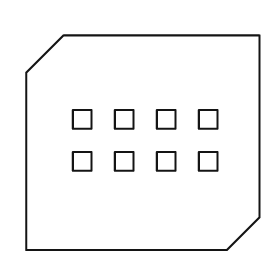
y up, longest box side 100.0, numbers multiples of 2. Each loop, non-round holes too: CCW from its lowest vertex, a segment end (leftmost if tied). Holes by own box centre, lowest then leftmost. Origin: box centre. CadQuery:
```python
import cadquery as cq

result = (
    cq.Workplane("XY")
    .moveTo(-50.0, -46.0)
    .lineTo(36.0, -46.0)
    .lineTo(50.0, -32.0)
    .lineTo(50.0, 46.0)
    .lineTo(-34.0, 46.0)
    .lineTo(-50.0, 30.0)
    .close()
    .moveTo(-30.0, -12.0)
    .lineTo(-22.0, -12.0)
    .lineTo(-22.0, -4.0)
    .lineTo(-30.0, -4.0)
    .close()
    .moveTo(-12.0, -12.0)
    .lineTo(-4.0, -12.0)
    .lineTo(-4.0, -4.0)
    .lineTo(-12.0, -4.0)
    .close()
    .moveTo(6.0, -12.0)
    .lineTo(14.0, -12.0)
    .lineTo(14.0, -4.0)
    .lineTo(6.0, -4.0)
    .close()
    .moveTo(24.0, -12.0)
    .lineTo(32.0, -12.0)
    .lineTo(32.0, -4.0)
    .lineTo(24.0, -4.0)
    .close()
    .moveTo(-30.0, 6.0)
    .lineTo(-22.0, 6.0)
    .lineTo(-22.0, 14.0)
    .lineTo(-30.0, 14.0)
    .close()
    .moveTo(-12.0, 6.0)
    .lineTo(-4.0, 6.0)
    .lineTo(-4.0, 14.0)
    .lineTo(-12.0, 14.0)
    .close()
    .moveTo(6.0, 6.0)
    .lineTo(14.0, 6.0)
    .lineTo(14.0, 14.0)
    .lineTo(6.0, 14.0)
    .close()
    .moveTo(24.0, 6.0)
    .lineTo(32.0, 6.0)
    .lineTo(32.0, 14.0)
    .lineTo(24.0, 14.0)
    .close()
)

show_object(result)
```